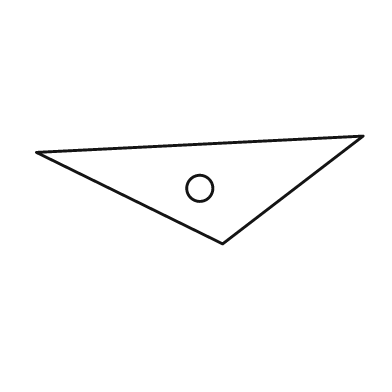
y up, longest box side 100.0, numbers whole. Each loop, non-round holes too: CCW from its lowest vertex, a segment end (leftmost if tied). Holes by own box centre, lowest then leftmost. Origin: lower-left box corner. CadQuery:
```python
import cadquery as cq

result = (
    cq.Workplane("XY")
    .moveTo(57.0, 0.0)
    .lineTo(100.0, 33.0)
    .lineTo(0.0, 28.0)
    .close()
    .moveTo(50.0, 17.0)
    .circle(4.0)
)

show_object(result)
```